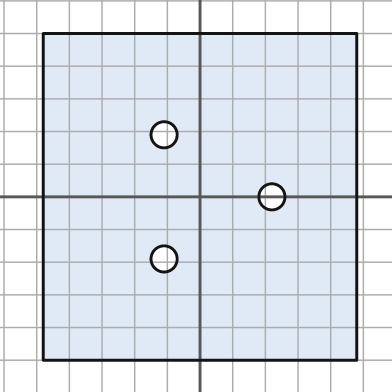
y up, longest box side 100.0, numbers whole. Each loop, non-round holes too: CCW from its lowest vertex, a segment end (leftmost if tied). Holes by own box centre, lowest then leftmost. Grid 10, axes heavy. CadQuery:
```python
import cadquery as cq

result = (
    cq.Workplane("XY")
    .moveTo(-48.0, -50.0)
    .lineTo(48.0, -50.0)
    .lineTo(48.0, 50.0)
    .lineTo(-48.0, 50.0)
    .close()
    .moveTo(-11.0, -19.0)
    .circle(4.0)
    .moveTo(22.0, 0.0)
    .circle(4.0)
    .moveTo(-11.0, 19.0)
    .circle(4.0)
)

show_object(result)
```